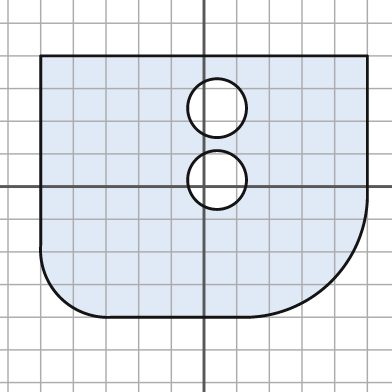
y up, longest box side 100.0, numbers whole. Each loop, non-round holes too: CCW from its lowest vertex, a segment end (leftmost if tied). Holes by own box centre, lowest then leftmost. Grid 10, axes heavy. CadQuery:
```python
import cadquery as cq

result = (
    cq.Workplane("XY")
    .moveTo(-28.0, -40.0)
    .lineTo(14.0, -40.0)
    .threePointArc((39.0, -29.0), (50.0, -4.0))
    .lineTo(50.0, 40.0)
    .lineTo(-50.0, 40.0)
    .lineTo(-50.0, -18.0)
    .threePointArc((-44.0, -34.0), (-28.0, -40.0))
    .close()
    .moveTo(4.0, 2.0)
    .circle(9.0)
    .moveTo(4.0, 24.0)
    .circle(9.0)
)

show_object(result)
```